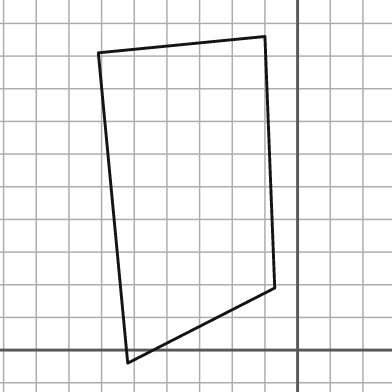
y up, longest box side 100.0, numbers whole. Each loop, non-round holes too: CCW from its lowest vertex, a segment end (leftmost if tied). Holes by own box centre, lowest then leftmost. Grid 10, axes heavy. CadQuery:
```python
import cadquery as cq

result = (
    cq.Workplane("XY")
    .moveTo(-52.0, -4.0)
    .lineTo(-7.0, 19.0)
    .lineTo(-10.0, 96.0)
    .lineTo(-61.0, 91.0)
    .close()
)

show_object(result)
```